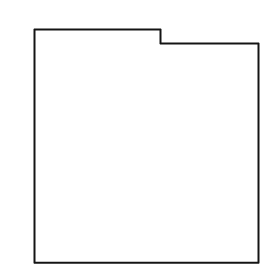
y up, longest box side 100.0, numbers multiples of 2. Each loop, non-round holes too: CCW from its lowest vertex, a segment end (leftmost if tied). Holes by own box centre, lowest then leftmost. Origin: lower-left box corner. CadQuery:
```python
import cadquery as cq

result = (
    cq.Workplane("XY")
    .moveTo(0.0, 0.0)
    .lineTo(96.0, 0.0)
    .lineTo(96.0, 94.0)
    .lineTo(54.0, 94.0)
    .lineTo(54.0, 100.0)
    .lineTo(0.0, 100.0)
    .close()
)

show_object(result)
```